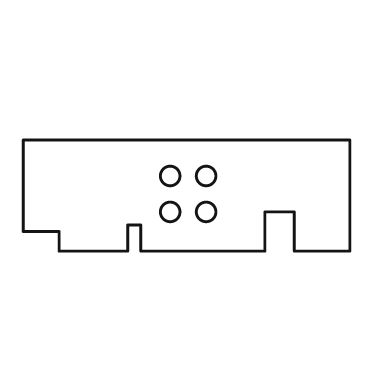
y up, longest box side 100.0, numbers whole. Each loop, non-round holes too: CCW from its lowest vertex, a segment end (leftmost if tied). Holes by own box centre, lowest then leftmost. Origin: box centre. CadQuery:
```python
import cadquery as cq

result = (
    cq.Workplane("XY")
    .moveTo(-39.0, -17.0)
    .lineTo(-18.0, -17.0)
    .lineTo(-18.0, -9.0)
    .lineTo(-14.0, -9.0)
    .lineTo(-14.0, -17.0)
    .lineTo(24.0, -17.0)
    .lineTo(24.0, -5.0)
    .lineTo(33.0, -5.0)
    .lineTo(33.0, -17.0)
    .lineTo(50.0, -17.0)
    .lineTo(50.0, 17.0)
    .lineTo(-50.0, 17.0)
    .lineTo(-50.0, -11.0)
    .lineTo(-39.0, -11.0)
    .close()
    .moveTo(-5.0, -5.0)
    .circle(3.0)
    .moveTo(6.0, -5.0)
    .circle(3.0)
    .moveTo(-5.0, 6.0)
    .circle(3.0)
    .moveTo(6.0, 6.0)
    .circle(3.0)
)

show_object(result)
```